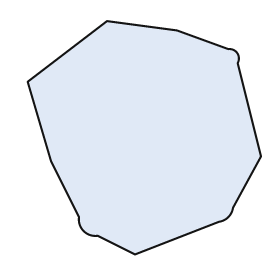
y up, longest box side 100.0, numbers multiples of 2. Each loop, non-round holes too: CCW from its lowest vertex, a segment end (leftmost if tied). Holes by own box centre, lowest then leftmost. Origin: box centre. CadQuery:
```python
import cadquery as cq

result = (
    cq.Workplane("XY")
    .moveTo(-4.0, -50.0)
    .lineTo(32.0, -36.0)
    .threePointArc((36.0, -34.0), (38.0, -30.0))
    .lineTo(50.0, -8.0)
    .lineTo(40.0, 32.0)
    .threePointArc((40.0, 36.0), (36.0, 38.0))
    .lineTo(14.0, 46.0)
    .lineTo(-16.0, 50.0)
    .lineTo(-50.0, 24.0)
    .lineTo(-40.0, -10.0)
    .lineTo(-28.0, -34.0)
    .threePointArc((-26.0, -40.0), (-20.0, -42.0))
    .close()
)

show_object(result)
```